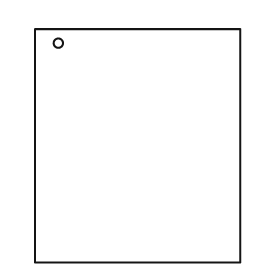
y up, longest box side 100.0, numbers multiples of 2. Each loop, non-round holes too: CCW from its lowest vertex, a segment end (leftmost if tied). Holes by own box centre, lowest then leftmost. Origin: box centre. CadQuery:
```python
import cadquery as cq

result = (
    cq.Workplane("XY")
    .moveTo(-44.0, -50.0)
    .lineTo(44.0, -50.0)
    .lineTo(44.0, 50.0)
    .lineTo(-44.0, 50.0)
    .close()
    .moveTo(-34.0, 44.0)
    .circle(2.0)
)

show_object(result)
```